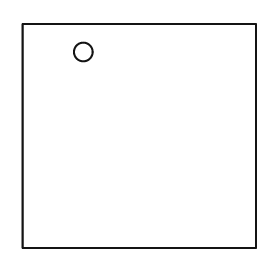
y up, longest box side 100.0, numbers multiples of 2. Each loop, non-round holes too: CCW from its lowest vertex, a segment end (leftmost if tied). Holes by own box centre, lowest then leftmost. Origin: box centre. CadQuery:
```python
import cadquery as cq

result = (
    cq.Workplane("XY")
    .moveTo(-50.0, -48.0)
    .lineTo(50.0, -48.0)
    .lineTo(50.0, 48.0)
    .lineTo(-50.0, 48.0)
    .close()
    .moveTo(-24.0, 36.0)
    .circle(4.0)
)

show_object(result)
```